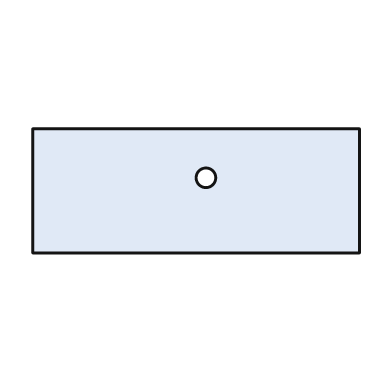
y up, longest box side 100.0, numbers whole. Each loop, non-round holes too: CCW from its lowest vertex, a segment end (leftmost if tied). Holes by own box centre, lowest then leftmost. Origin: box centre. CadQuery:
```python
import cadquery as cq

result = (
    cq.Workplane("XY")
    .moveTo(-50.0, -19.0)
    .lineTo(50.0, -19.0)
    .lineTo(50.0, 19.0)
    .lineTo(-50.0, 19.0)
    .close()
    .moveTo(3.0, 4.0)
    .circle(3.0)
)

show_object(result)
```